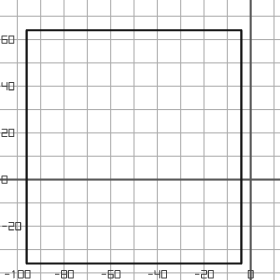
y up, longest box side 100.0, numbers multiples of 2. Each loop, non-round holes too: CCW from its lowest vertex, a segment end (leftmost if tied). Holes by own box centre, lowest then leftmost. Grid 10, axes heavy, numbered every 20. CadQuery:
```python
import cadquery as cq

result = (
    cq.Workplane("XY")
    .moveTo(-96.0, -36.0)
    .lineTo(-4.0, -36.0)
    .lineTo(-4.0, 64.0)
    .lineTo(-96.0, 64.0)
    .close()
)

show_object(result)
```